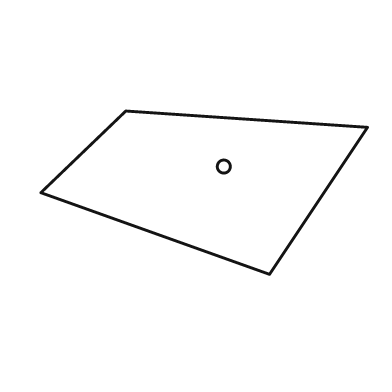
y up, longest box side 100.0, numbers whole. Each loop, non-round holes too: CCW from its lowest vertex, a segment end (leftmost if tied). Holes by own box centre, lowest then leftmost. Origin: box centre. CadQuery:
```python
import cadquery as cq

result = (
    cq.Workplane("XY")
    .moveTo(20.0, -25.0)
    .lineTo(50.0, 20.0)
    .lineTo(-24.0, 25.0)
    .lineTo(-50.0, 0.0)
    .close()
    .moveTo(6.0, 8.0)
    .circle(2.0)
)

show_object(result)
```